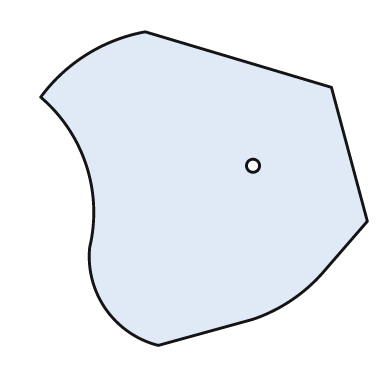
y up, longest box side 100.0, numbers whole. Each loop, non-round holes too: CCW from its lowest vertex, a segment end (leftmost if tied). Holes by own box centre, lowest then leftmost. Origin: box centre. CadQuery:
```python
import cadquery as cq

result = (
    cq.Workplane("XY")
    .moveTo(-14.0, -48.0)
    .lineTo(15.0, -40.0)
    .threePointArc((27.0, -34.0), (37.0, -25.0))
    .lineTo(50.0, -10.0)
    .lineTo(39.0, 31.0)
    .lineTo(-18.0, 48.0)
    .threePointArc((-36.0, 41.0), (-50.0, 28.0))
    .threePointArc((-36.0, 7.0), (-35.0, -18.0))
    .threePointArc((-30.0, -37.0), (-14.0, -48.0))
    .close()
    .moveTo(15.0, 7.0)
    .circle(2.0)
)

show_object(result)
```